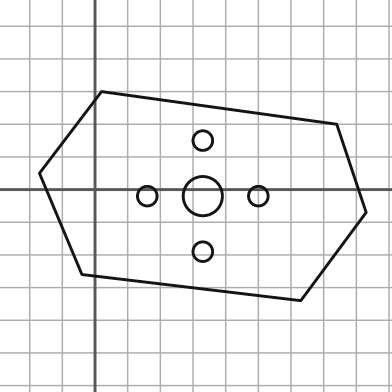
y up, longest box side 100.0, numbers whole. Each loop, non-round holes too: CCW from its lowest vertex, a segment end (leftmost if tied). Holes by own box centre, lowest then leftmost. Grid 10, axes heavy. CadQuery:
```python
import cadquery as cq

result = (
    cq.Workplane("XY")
    .moveTo(63.0, -34.0)
    .lineTo(83.0, -7.0)
    .lineTo(74.0, 20.0)
    .lineTo(2.0, 30.0)
    .lineTo(-17.0, 5.0)
    .lineTo(-4.0, -26.0)
    .close()
    .moveTo(33.0, -19.0)
    .circle(3.0)
    .moveTo(16.0, -2.0)
    .circle(3.0)
    .moveTo(33.0, -2.0)
    .circle(6.0)
    .moveTo(50.0, -2.0)
    .circle(3.0)
    .moveTo(33.0, 15.0)
    .circle(3.0)
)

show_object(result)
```